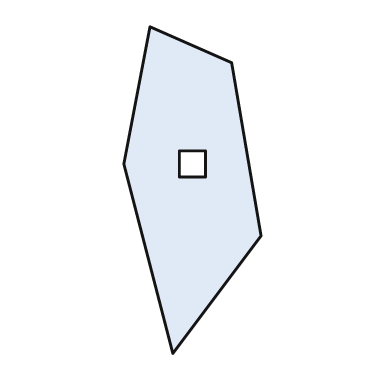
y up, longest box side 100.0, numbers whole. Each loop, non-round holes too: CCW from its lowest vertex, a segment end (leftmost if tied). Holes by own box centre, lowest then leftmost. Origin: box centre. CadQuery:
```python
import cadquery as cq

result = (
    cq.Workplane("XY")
    .moveTo(-6.0, -50.0)
    .lineTo(21.0, -14.0)
    .lineTo(12.0, 39.0)
    .lineTo(-13.0, 50.0)
    .lineTo(-21.0, 8.0)
    .close()
    .moveTo(-4.0, 4.0)
    .lineTo(4.0, 4.0)
    .lineTo(4.0, 12.0)
    .lineTo(-4.0, 12.0)
    .close()
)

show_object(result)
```